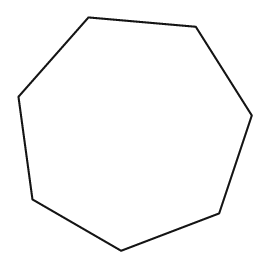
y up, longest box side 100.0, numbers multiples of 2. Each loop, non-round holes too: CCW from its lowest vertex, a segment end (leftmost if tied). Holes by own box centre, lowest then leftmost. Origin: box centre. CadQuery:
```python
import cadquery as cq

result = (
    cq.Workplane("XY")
    .moveTo(-6.0, -50.0)
    .lineTo(36.0, -34.0)
    .lineTo(50.0, 8.0)
    .lineTo(26.0, 46.0)
    .lineTo(-20.0, 50.0)
    .lineTo(-50.0, 16.0)
    .lineTo(-44.0, -28.0)
    .close()
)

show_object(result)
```